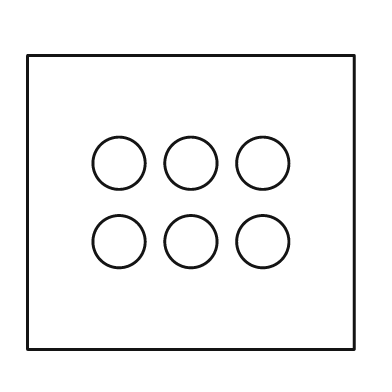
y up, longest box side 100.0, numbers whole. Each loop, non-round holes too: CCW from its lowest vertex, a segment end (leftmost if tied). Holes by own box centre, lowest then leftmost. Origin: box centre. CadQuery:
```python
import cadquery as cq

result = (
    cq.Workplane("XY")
    .moveTo(-50.0, -45.0)
    .lineTo(50.0, -45.0)
    .lineTo(50.0, 45.0)
    .lineTo(-50.0, 45.0)
    .close()
    .moveTo(-22.0, -12.0)
    .circle(8.0)
    .moveTo(0.0, -12.0)
    .circle(8.0)
    .moveTo(22.0, -12.0)
    .circle(8.0)
    .moveTo(-22.0, 12.0)
    .circle(8.0)
    .moveTo(0.0, 12.0)
    .circle(8.0)
    .moveTo(22.0, 12.0)
    .circle(8.0)
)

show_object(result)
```